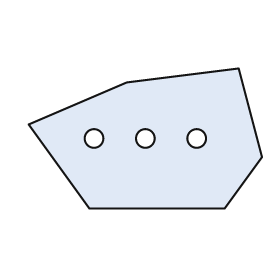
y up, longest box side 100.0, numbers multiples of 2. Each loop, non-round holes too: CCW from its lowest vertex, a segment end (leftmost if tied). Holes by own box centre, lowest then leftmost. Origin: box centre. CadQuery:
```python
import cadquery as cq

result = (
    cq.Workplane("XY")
    .moveTo(-24.0, -30.0)
    .lineTo(34.0, -30.0)
    .lineTo(50.0, -8.0)
    .lineTo(40.0, 30.0)
    .lineTo(-8.0, 24.0)
    .lineTo(-50.0, 6.0)
    .close()
    .moveTo(-22.0, 0.0)
    .circle(4.0)
    .moveTo(0.0, 0.0)
    .circle(4.0)
    .moveTo(22.0, 0.0)
    .circle(4.0)
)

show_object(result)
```